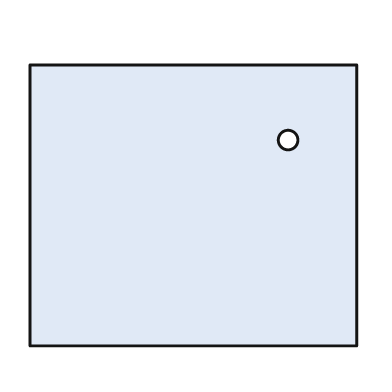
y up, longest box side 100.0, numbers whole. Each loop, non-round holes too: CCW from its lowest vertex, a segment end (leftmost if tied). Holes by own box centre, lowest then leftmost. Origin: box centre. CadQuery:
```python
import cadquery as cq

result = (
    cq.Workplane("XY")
    .moveTo(-50.0, -43.0)
    .lineTo(50.0, -43.0)
    .lineTo(50.0, 43.0)
    .lineTo(-50.0, 43.0)
    .close()
    .moveTo(29.0, 20.0)
    .circle(3.0)
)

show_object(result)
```